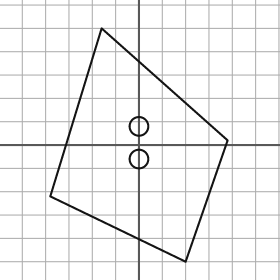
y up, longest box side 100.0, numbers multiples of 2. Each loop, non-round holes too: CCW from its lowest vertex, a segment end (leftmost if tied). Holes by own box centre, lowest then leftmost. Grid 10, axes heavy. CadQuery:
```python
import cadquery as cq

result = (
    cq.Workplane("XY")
    .moveTo(20.0, -50.0)
    .lineTo(38.0, 2.0)
    .lineTo(-16.0, 50.0)
    .lineTo(-38.0, -22.0)
    .close()
    .moveTo(0.0, -6.0)
    .circle(4.0)
    .moveTo(0.0, 8.0)
    .circle(4.0)
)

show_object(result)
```